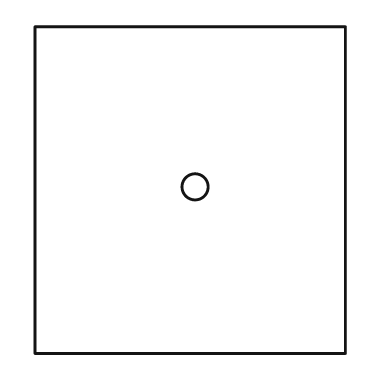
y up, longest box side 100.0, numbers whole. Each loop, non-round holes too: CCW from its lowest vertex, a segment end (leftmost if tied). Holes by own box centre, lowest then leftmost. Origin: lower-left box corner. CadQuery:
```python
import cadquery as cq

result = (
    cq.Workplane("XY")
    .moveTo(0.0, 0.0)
    .lineTo(95.0, 0.0)
    .lineTo(95.0, 100.0)
    .lineTo(0.0, 100.0)
    .close()
    .moveTo(49.0, 51.0)
    .circle(4.0)
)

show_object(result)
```